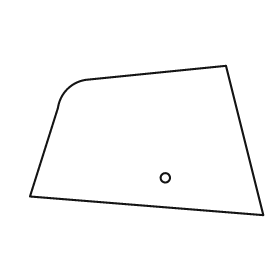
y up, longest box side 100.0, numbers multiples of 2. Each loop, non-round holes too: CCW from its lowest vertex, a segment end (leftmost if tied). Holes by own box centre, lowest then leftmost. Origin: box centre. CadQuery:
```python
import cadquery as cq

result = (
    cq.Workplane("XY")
    .moveTo(50.0, -32.0)
    .lineTo(34.0, 32.0)
    .lineTo(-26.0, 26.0)
    .threePointArc((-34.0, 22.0), (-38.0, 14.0))
    .lineTo(-50.0, -24.0)
    .close()
    .moveTo(8.0, -16.0)
    .circle(2.0)
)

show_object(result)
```